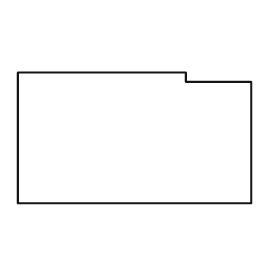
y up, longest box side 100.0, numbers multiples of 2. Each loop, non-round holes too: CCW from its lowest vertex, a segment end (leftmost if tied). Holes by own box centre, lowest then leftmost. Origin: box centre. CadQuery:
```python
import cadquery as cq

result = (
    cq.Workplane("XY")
    .moveTo(-50.0, -28.0)
    .lineTo(50.0, -28.0)
    .lineTo(50.0, 24.0)
    .lineTo(22.0, 24.0)
    .lineTo(22.0, 28.0)
    .lineTo(-50.0, 28.0)
    .close()
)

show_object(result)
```